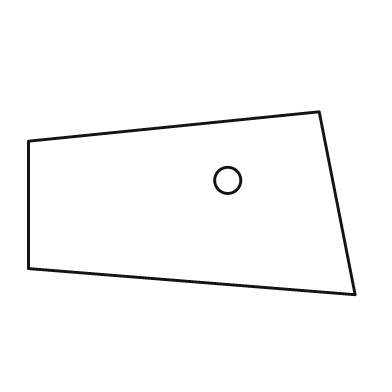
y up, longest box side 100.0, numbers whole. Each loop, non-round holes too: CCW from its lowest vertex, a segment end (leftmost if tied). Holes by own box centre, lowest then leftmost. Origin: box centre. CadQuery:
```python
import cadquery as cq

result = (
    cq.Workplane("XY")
    .moveTo(50.0, -28.0)
    .lineTo(39.0, 28.0)
    .lineTo(-50.0, 19.0)
    .lineTo(-50.0, -20.0)
    .close()
    .moveTo(11.0, 7.0)
    .circle(4.0)
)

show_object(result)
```